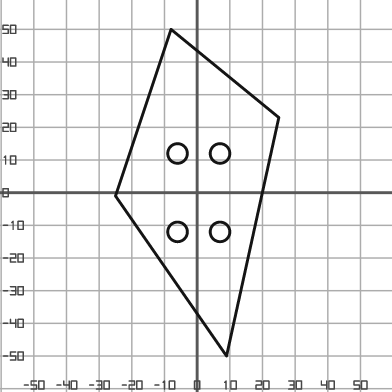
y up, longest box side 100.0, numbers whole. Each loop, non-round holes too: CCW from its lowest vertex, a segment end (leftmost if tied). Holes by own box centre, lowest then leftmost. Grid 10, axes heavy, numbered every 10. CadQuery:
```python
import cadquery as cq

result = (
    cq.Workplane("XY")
    .moveTo(9.0, -50.0)
    .lineTo(25.0, 23.0)
    .lineTo(-8.0, 50.0)
    .lineTo(-25.0, -1.0)
    .close()
    .moveTo(-6.0, -12.0)
    .circle(3.0)
    .moveTo(7.0, -12.0)
    .circle(3.0)
    .moveTo(-6.0, 12.0)
    .circle(3.0)
    .moveTo(7.0, 12.0)
    .circle(3.0)
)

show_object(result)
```